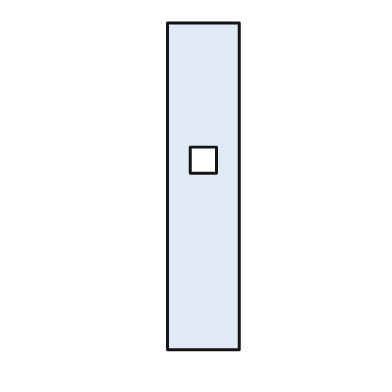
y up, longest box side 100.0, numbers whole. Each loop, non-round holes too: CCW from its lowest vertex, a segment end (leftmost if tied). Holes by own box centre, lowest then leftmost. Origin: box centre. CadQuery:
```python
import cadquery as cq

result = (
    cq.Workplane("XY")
    .moveTo(-11.0, -50.0)
    .lineTo(11.0, -50.0)
    .lineTo(11.0, 50.0)
    .lineTo(-11.0, 50.0)
    .close()
    .moveTo(-4.0, 4.0)
    .lineTo(4.0, 4.0)
    .lineTo(4.0, 12.0)
    .lineTo(-4.0, 12.0)
    .close()
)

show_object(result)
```